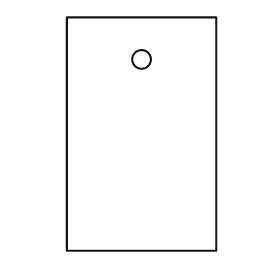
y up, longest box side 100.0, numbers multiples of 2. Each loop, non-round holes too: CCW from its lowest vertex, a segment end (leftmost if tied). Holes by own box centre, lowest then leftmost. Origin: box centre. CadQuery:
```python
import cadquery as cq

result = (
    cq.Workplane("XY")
    .moveTo(-32.0, -50.0)
    .lineTo(32.0, -50.0)
    .lineTo(32.0, 50.0)
    .lineTo(-32.0, 50.0)
    .close()
    .moveTo(0.0, 32.0)
    .circle(4.0)
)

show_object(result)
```